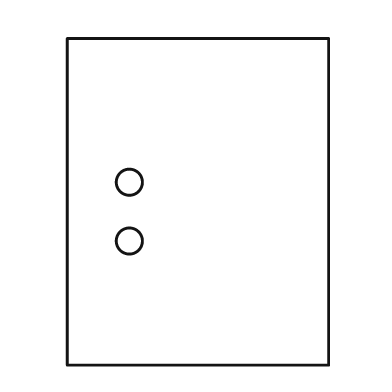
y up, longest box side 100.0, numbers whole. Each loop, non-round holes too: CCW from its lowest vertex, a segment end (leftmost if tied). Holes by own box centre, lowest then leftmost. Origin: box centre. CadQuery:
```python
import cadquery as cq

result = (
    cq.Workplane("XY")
    .moveTo(-40.0, -50.0)
    .lineTo(40.0, -50.0)
    .lineTo(40.0, 50.0)
    .lineTo(-40.0, 50.0)
    .close()
    .moveTo(-21.0, -12.0)
    .circle(4.0)
    .moveTo(-21.0, 6.0)
    .circle(4.0)
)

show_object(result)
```